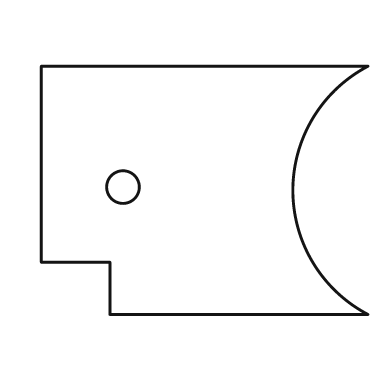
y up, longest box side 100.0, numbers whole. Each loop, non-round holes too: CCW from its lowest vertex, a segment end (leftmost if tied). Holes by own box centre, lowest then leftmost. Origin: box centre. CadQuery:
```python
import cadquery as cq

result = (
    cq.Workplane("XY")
    .moveTo(-29.0, -38.0)
    .lineTo(50.0, -38.0)
    .threePointArc((27.0, 0.0), (50.0, 38.0))
    .lineTo(-50.0, 38.0)
    .lineTo(-50.0, -22.0)
    .lineTo(-29.0, -22.0)
    .close()
    .moveTo(-25.0, 1.0)
    .circle(5.0)
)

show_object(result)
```